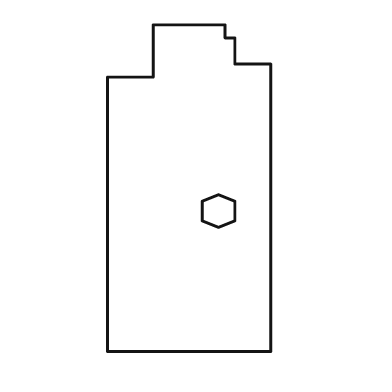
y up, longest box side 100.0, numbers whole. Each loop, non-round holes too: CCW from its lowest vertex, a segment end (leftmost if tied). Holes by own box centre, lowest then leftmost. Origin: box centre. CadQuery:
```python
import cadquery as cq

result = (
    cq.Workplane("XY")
    .moveTo(-25.0, -50.0)
    .lineTo(25.0, -50.0)
    .lineTo(25.0, 38.0)
    .lineTo(14.0, 38.0)
    .lineTo(14.0, 46.0)
    .lineTo(11.0, 46.0)
    .lineTo(11.0, 50.0)
    .lineTo(-11.0, 50.0)
    .lineTo(-11.0, 34.0)
    .lineTo(-25.0, 34.0)
    .close()
    .moveTo(9.0, -12.0)
    .lineTo(14.0, -10.0)
    .lineTo(14.0, -4.0)
    .lineTo(9.0, -2.0)
    .lineTo(4.0, -4.0)
    .lineTo(4.0, -10.0)
    .close()
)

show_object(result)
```